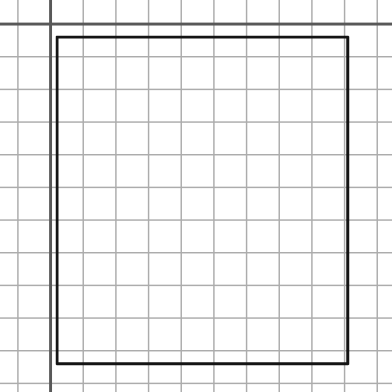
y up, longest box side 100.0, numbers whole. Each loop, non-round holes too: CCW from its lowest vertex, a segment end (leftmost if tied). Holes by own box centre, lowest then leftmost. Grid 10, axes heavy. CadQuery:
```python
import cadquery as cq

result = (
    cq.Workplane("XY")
    .moveTo(2.0, -104.0)
    .lineTo(91.0, -104.0)
    .lineTo(91.0, -4.0)
    .lineTo(2.0, -4.0)
    .close()
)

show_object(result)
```